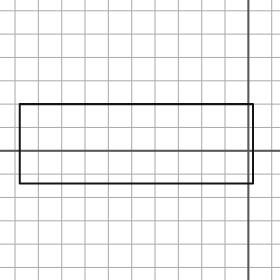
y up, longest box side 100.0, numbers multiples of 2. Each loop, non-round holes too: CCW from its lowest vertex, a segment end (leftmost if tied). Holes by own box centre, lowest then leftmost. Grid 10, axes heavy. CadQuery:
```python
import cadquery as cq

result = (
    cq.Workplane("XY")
    .moveTo(-98.0, -14.0)
    .lineTo(2.0, -14.0)
    .lineTo(2.0, 20.0)
    .lineTo(-98.0, 20.0)
    .close()
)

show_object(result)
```